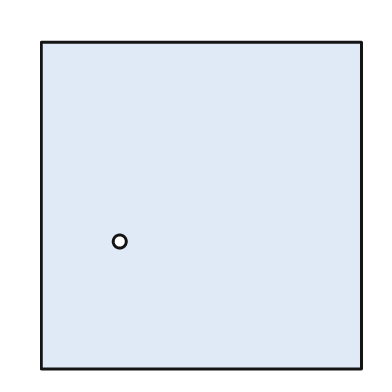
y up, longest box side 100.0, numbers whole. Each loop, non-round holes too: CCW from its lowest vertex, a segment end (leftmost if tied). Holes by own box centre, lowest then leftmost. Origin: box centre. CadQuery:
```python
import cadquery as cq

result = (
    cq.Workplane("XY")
    .moveTo(-49.0, -50.0)
    .lineTo(49.0, -50.0)
    .lineTo(49.0, 50.0)
    .lineTo(-49.0, 50.0)
    .close()
    .moveTo(-25.0, -11.0)
    .circle(2.0)
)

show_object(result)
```